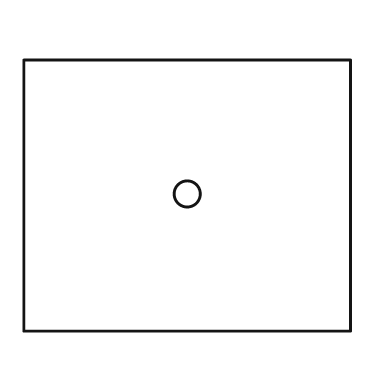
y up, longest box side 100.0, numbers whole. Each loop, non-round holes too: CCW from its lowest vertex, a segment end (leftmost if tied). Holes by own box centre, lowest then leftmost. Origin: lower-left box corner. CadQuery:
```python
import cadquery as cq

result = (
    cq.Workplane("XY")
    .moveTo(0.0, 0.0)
    .lineTo(100.0, 0.0)
    .lineTo(100.0, 83.0)
    .lineTo(0.0, 83.0)
    .close()
    .moveTo(50.0, 42.0)
    .circle(4.0)
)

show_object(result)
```